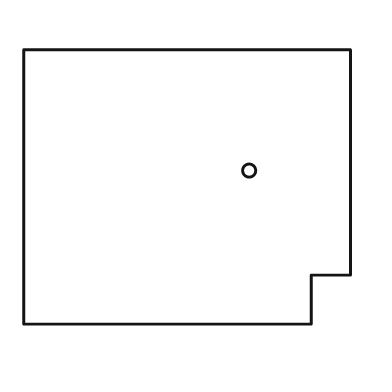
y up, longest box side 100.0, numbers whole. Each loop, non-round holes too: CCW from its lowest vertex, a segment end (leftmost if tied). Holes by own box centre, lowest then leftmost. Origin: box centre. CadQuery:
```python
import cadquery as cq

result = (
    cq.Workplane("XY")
    .moveTo(-50.0, -42.0)
    .lineTo(38.0, -42.0)
    .lineTo(38.0, -27.0)
    .lineTo(50.0, -27.0)
    .lineTo(50.0, 42.0)
    .lineTo(-50.0, 42.0)
    .close()
    .moveTo(19.0, 5.0)
    .circle(2.0)
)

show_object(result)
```